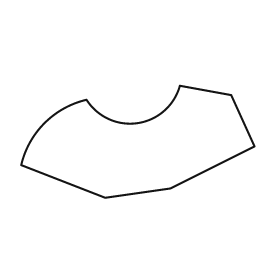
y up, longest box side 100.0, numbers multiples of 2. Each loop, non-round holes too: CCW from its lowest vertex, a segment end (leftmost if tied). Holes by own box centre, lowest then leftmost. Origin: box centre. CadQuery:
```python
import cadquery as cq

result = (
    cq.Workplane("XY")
    .moveTo(-14.0, -24.0)
    .lineTo(14.0, -20.0)
    .lineTo(50.0, -2.0)
    .lineTo(40.0, 20.0)
    .lineTo(18.0, 24.0)
    .threePointArc((0.0, 8.0), (-22.0, 18.0))
    .threePointArc((-40.0, 8.0), (-50.0, -10.0))
    .close()
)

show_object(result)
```